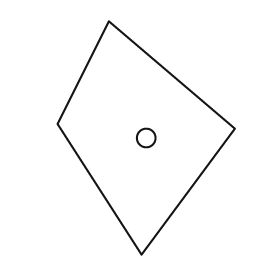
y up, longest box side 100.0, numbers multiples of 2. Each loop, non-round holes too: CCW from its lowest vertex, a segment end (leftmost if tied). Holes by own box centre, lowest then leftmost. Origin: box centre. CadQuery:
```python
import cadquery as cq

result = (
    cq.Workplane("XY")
    .moveTo(-2.0, -50.0)
    .lineTo(38.0, 4.0)
    .lineTo(-16.0, 50.0)
    .lineTo(-38.0, 6.0)
    .close()
    .moveTo(0.0, 0.0)
    .circle(4.0)
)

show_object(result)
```